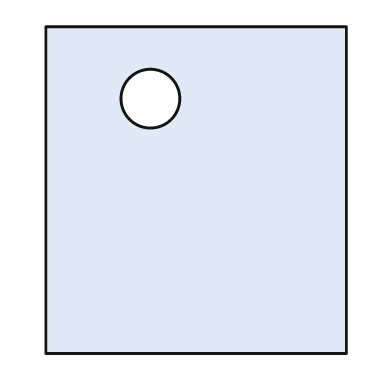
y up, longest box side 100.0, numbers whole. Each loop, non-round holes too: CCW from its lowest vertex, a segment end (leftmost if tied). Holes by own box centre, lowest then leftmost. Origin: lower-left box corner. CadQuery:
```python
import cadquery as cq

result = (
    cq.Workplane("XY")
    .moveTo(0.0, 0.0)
    .lineTo(92.0, 0.0)
    .lineTo(92.0, 100.0)
    .lineTo(0.0, 100.0)
    .close()
    .moveTo(32.0, 78.0)
    .circle(9.0)
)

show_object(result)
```